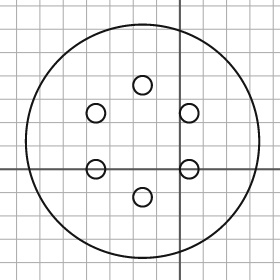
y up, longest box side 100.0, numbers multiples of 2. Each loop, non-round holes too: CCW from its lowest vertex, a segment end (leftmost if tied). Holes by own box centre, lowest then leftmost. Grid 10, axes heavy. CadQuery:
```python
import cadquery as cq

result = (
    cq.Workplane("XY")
    .moveTo(-16.0, 12.0)
    .circle(50.0)
    .moveTo(-16.0, -12.0)
    .circle(4.0)
    .moveTo(-36.0, 0.0)
    .circle(4.0)
    .moveTo(4.0, 0.0)
    .circle(4.0)
    .moveTo(-36.0, 24.0)
    .circle(4.0)
    .moveTo(4.0, 24.0)
    .circle(4.0)
    .moveTo(-16.0, 36.0)
    .circle(4.0)
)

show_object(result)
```